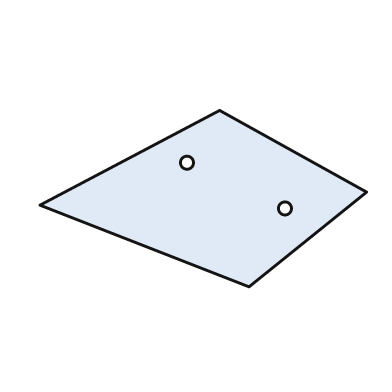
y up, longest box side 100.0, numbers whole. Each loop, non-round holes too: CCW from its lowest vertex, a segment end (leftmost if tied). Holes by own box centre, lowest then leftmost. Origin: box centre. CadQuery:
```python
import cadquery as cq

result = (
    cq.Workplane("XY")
    .moveTo(14.0, -27.0)
    .lineTo(50.0, 2.0)
    .lineTo(5.0, 27.0)
    .lineTo(-50.0, -2.0)
    .close()
    .moveTo(25.0, -3.0)
    .circle(2.0)
    .moveTo(-5.0, 11.0)
    .circle(2.0)
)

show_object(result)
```